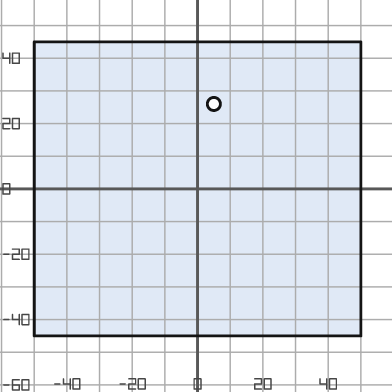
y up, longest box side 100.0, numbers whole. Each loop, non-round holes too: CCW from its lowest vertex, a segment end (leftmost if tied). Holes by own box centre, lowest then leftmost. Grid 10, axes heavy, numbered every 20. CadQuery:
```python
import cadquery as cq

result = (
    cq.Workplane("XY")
    .moveTo(-50.0, -45.0)
    .lineTo(50.0, -45.0)
    .lineTo(50.0, 45.0)
    .lineTo(-50.0, 45.0)
    .close()
    .moveTo(5.0, 26.0)
    .circle(2.0)
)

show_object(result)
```